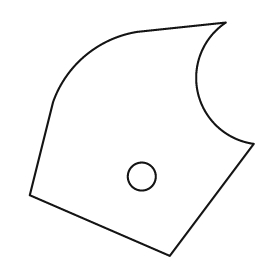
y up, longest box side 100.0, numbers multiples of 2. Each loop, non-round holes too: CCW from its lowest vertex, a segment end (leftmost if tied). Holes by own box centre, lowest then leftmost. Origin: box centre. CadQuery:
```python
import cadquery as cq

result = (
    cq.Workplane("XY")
    .moveTo(12.0, -50.0)
    .lineTo(48.0, -2.0)
    .threePointArc((24.0, 20.0), (36.0, 50.0))
    .lineTo(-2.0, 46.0)
    .threePointArc((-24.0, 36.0), (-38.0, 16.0))
    .lineTo(-48.0, -24.0)
    .close()
    .moveTo(0.0, -16.0)
    .circle(6.0)
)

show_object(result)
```